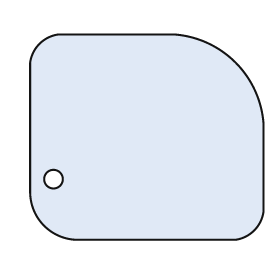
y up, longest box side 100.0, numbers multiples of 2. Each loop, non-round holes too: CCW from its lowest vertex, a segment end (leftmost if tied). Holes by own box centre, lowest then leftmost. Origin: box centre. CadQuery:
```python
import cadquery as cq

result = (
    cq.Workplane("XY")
    .moveTo(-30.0, -44.0)
    .lineTo(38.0, -44.0)
    .threePointArc((46.0, -40.0), (50.0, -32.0))
    .lineTo(50.0, 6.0)
    .threePointArc((38.0, 32.0), (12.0, 44.0))
    .lineTo(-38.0, 44.0)
    .threePointArc((-46.0, 40.0), (-50.0, 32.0))
    .lineTo(-50.0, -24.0)
    .threePointArc((-44.0, -38.0), (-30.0, -44.0))
    .close()
    .moveTo(-40.0, -18.0)
    .circle(4.0)
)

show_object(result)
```